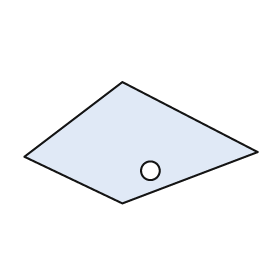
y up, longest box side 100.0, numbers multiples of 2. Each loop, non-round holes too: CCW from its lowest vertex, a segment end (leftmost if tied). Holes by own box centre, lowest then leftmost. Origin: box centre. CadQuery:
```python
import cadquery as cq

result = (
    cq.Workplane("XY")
    .moveTo(-8.0, -26.0)
    .lineTo(50.0, -4.0)
    .lineTo(-8.0, 26.0)
    .lineTo(-50.0, -6.0)
    .close()
    .moveTo(4.0, -12.0)
    .circle(4.0)
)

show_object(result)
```